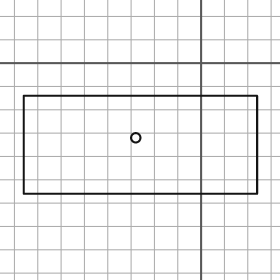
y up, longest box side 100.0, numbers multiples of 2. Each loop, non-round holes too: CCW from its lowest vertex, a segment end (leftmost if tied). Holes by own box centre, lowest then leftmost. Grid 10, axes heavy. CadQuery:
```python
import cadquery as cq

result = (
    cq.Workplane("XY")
    .moveTo(-76.0, -56.0)
    .lineTo(24.0, -56.0)
    .lineTo(24.0, -14.0)
    .lineTo(-76.0, -14.0)
    .close()
    .moveTo(-28.0, -32.0)
    .circle(2.0)
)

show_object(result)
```